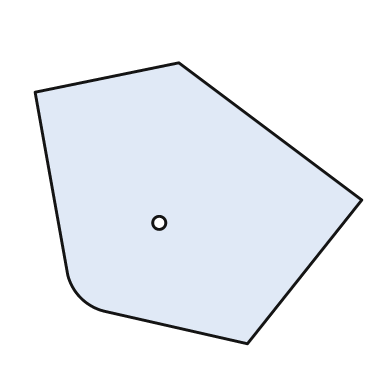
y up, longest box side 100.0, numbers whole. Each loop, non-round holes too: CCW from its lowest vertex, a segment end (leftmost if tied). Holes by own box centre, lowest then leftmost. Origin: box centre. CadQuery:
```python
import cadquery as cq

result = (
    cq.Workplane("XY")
    .moveTo(15.0, -43.0)
    .lineTo(50.0, 1.0)
    .lineTo(-6.0, 43.0)
    .lineTo(-50.0, 34.0)
    .lineTo(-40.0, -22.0)
    .threePointArc((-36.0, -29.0), (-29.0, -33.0))
    .close()
    .moveTo(-12.0, -6.0)
    .circle(2.0)
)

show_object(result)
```